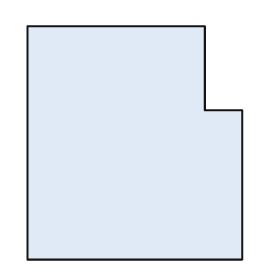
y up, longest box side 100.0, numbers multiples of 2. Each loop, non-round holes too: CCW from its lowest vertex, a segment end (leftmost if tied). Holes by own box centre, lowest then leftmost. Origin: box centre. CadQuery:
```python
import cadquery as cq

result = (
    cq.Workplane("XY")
    .moveTo(-46.0, -50.0)
    .lineTo(46.0, -50.0)
    .lineTo(46.0, 14.0)
    .lineTo(30.0, 14.0)
    .lineTo(30.0, 50.0)
    .lineTo(-46.0, 50.0)
    .close()
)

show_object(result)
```